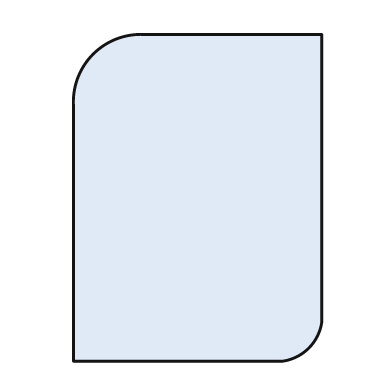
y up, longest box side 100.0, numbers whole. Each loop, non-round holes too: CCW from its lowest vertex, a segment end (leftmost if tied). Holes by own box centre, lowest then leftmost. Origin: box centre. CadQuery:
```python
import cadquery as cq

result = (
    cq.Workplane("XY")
    .moveTo(-38.0, -50.0)
    .lineTo(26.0, -50.0)
    .threePointArc((34.0, -46.0), (38.0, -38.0))
    .lineTo(38.0, 50.0)
    .lineTo(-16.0, 50.0)
    .threePointArc((-32.0, 44.0), (-38.0, 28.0))
    .close()
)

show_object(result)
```